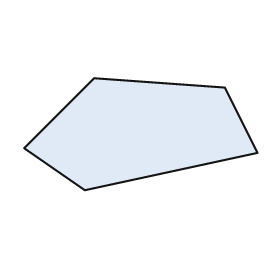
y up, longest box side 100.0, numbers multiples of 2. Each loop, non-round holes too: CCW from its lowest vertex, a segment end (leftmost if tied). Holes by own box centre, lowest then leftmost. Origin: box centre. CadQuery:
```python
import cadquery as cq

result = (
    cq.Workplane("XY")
    .moveTo(-24.0, -24.0)
    .lineTo(50.0, -8.0)
    .lineTo(36.0, 20.0)
    .lineTo(-20.0, 24.0)
    .lineTo(-50.0, -6.0)
    .close()
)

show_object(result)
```